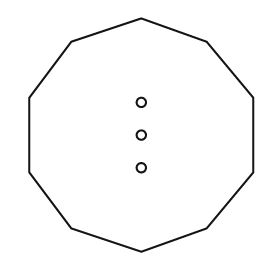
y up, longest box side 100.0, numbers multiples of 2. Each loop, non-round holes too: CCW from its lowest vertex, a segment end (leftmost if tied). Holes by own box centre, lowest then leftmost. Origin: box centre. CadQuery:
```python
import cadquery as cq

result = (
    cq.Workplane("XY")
    .moveTo(0.0, -50.0)
    .lineTo(28.0, -40.0)
    .lineTo(48.0, -16.0)
    .lineTo(48.0, 16.0)
    .lineTo(28.0, 40.0)
    .lineTo(0.0, 50.0)
    .lineTo(-30.0, 40.0)
    .lineTo(-48.0, 16.0)
    .lineTo(-48.0, -16.0)
    .lineTo(-30.0, -40.0)
    .close()
    .moveTo(0.0, -14.0)
    .circle(2.0)
    .moveTo(0.0, 0.0)
    .circle(2.0)
    .moveTo(0.0, 14.0)
    .circle(2.0)
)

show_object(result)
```